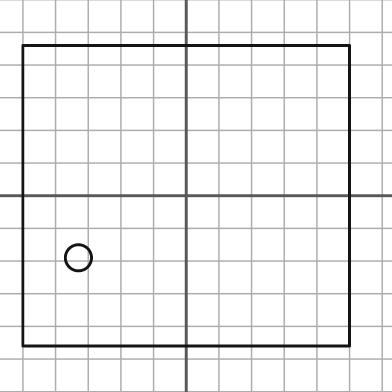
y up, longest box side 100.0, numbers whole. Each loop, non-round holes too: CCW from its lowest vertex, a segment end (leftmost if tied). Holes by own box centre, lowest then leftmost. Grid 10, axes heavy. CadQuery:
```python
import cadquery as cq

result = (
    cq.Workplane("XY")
    .moveTo(-50.0, -46.0)
    .lineTo(50.0, -46.0)
    .lineTo(50.0, 46.0)
    .lineTo(-50.0, 46.0)
    .close()
    .moveTo(-33.0, -19.0)
    .circle(4.0)
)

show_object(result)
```